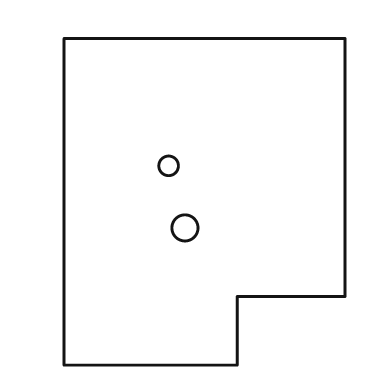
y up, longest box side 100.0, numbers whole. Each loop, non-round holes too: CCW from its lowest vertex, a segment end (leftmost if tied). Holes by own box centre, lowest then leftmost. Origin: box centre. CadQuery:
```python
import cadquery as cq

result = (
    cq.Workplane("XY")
    .moveTo(-43.0, -50.0)
    .lineTo(10.0, -50.0)
    .lineTo(10.0, -29.0)
    .lineTo(43.0, -29.0)
    .lineTo(43.0, 50.0)
    .lineTo(-43.0, 50.0)
    .close()
    .moveTo(-6.0, -8.0)
    .circle(4.0)
    .moveTo(-11.0, 11.0)
    .circle(3.0)
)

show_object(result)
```